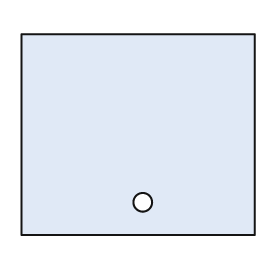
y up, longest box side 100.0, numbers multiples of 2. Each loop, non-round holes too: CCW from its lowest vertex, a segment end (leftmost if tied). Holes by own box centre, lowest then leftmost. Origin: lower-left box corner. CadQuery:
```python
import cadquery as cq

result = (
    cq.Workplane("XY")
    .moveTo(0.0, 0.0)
    .lineTo(100.0, 0.0)
    .lineTo(100.0, 86.0)
    .lineTo(0.0, 86.0)
    .close()
    .moveTo(52.0, 14.0)
    .circle(4.0)
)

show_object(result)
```